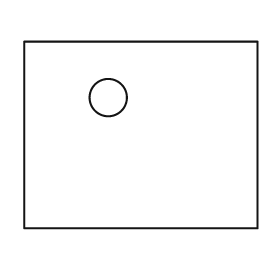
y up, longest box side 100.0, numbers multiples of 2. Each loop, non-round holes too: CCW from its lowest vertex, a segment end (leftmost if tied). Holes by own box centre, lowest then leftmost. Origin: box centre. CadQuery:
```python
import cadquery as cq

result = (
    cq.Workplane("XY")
    .moveTo(-50.0, -40.0)
    .lineTo(50.0, -40.0)
    .lineTo(50.0, 40.0)
    .lineTo(-50.0, 40.0)
    .close()
    .moveTo(-14.0, 16.0)
    .circle(8.0)
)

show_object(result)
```